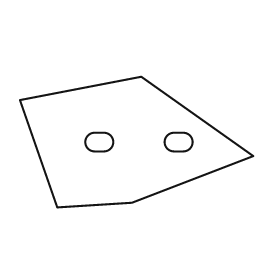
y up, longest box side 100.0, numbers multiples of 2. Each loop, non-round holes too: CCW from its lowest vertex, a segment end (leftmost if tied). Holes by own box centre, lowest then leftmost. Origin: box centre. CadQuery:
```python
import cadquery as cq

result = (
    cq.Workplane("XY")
    .moveTo(-34.0, -28.0)
    .lineTo(-2.0, -26.0)
    .lineTo(50.0, -6.0)
    .lineTo(2.0, 28.0)
    .lineTo(-50.0, 18.0)
    .close()
    .moveTo(-18.0, -4.0)
    .lineTo(-14.0, -4.0)
    .threePointArc((-10.0, 0.0), (-14.0, 4.0))
    .lineTo(-18.0, 4.0)
    .threePointArc((-22.0, 0.0), (-18.0, -4.0))
    .close()
    .moveTo(16.0, -4.0)
    .lineTo(20.0, -4.0)
    .threePointArc((24.0, 0.0), (20.0, 4.0))
    .lineTo(16.0, 4.0)
    .threePointArc((12.0, 0.0), (16.0, -4.0))
    .close()
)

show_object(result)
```